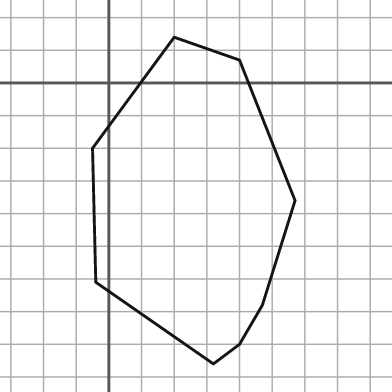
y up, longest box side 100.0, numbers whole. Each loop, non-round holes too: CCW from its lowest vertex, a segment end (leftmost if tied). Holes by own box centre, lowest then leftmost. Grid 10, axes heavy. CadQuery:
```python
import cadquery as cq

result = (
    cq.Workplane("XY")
    .moveTo(32.0, -86.0)
    .lineTo(40.0, -80.0)
    .lineTo(47.0, -68.0)
    .lineTo(57.0, -36.0)
    .lineTo(40.0, 7.0)
    .lineTo(20.0, 14.0)
    .lineTo(-5.0, -20.0)
    .lineTo(-4.0, -61.0)
    .close()
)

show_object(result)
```